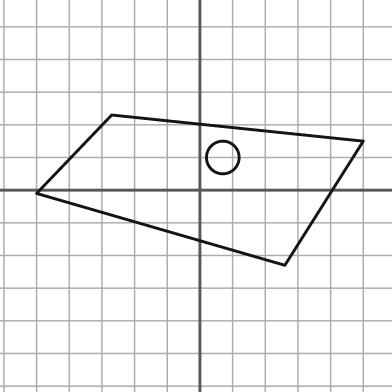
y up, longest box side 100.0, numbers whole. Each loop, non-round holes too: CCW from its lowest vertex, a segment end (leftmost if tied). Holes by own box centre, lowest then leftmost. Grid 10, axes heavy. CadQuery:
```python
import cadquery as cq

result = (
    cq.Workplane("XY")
    .moveTo(26.0, -23.0)
    .lineTo(50.0, 15.0)
    .lineTo(-27.0, 23.0)
    .lineTo(-50.0, -1.0)
    .close()
    .moveTo(7.0, 10.0)
    .circle(5.0)
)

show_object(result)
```